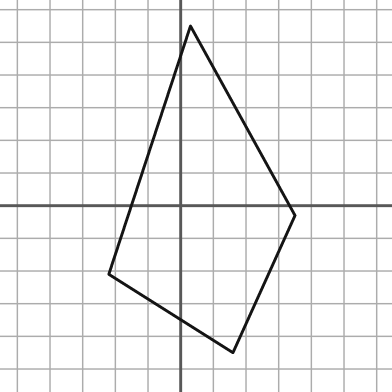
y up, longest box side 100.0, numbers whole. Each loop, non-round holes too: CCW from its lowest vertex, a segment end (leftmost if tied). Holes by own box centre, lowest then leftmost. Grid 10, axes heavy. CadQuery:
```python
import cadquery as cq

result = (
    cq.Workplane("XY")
    .moveTo(16.0, -45.0)
    .lineTo(35.0, -3.0)
    .lineTo(3.0, 55.0)
    .lineTo(-22.0, -21.0)
    .close()
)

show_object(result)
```